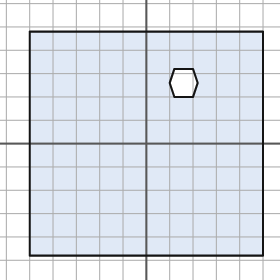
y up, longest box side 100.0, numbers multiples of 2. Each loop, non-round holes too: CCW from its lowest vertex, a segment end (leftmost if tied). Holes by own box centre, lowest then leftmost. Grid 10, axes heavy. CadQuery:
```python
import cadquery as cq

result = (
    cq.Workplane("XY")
    .moveTo(-50.0, -48.0)
    .lineTo(50.0, -48.0)
    .lineTo(50.0, 48.0)
    .lineTo(-50.0, 48.0)
    .close()
    .moveTo(12.0, 20.0)
    .lineTo(20.0, 20.0)
    .lineTo(22.0, 26.0)
    .lineTo(20.0, 32.0)
    .lineTo(12.0, 32.0)
    .lineTo(10.0, 26.0)
    .close()
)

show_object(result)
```